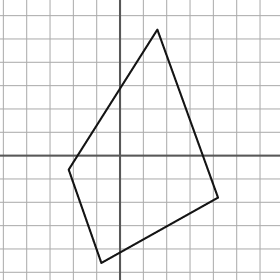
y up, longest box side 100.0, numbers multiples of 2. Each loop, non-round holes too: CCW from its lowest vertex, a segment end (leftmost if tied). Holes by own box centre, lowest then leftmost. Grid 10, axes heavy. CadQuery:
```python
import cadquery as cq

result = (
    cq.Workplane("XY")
    .moveTo(-8.0, -46.0)
    .lineTo(42.0, -18.0)
    .lineTo(16.0, 54.0)
    .lineTo(-22.0, -6.0)
    .close()
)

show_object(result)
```